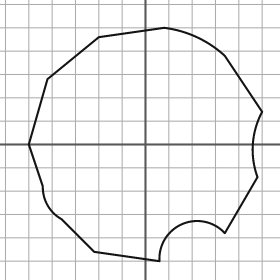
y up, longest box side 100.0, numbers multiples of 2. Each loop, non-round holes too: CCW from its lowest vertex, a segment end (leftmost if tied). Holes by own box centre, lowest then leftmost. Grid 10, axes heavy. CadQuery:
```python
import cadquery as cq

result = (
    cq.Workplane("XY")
    .moveTo(6.0, -50.0)
    .threePointArc((16.0, -34.0), (34.0, -38.0))
    .lineTo(48.0, -14.0)
    .threePointArc((46.0, 0.0), (50.0, 14.0))
    .lineTo(34.0, 38.0)
    .threePointArc((22.0, 46.0), (8.0, 50.0))
    .lineTo(-20.0, 46.0)
    .lineTo(-42.0, 28.0)
    .lineTo(-50.0, 0.0)
    .lineTo(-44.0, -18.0)
    .threePointArc((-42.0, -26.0), (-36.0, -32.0))
    .lineTo(-22.0, -46.0)
    .close()
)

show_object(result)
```